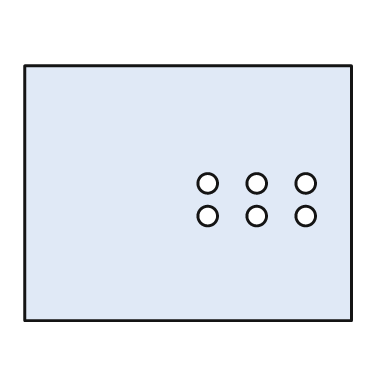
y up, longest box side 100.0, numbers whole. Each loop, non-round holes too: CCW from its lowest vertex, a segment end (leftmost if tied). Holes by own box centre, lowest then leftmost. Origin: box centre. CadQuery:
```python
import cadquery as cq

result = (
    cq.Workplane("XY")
    .moveTo(-50.0, -39.0)
    .lineTo(50.0, -39.0)
    .lineTo(50.0, 39.0)
    .lineTo(-50.0, 39.0)
    .close()
    .moveTo(6.0, -7.0)
    .circle(3.0)
    .moveTo(21.0, -7.0)
    .circle(3.0)
    .moveTo(36.0, -7.0)
    .circle(3.0)
    .moveTo(6.0, 3.0)
    .circle(3.0)
    .moveTo(21.0, 3.0)
    .circle(3.0)
    .moveTo(36.0, 3.0)
    .circle(3.0)
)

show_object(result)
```